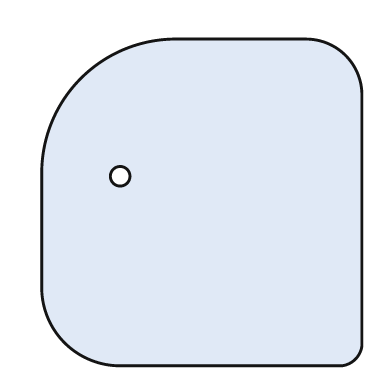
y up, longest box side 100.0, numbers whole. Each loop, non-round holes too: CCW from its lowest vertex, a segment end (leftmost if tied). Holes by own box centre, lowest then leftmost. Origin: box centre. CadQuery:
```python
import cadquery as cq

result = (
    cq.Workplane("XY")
    .moveTo(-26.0, -50.0)
    .lineTo(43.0, -50.0)
    .threePointArc((47.0, -48.0), (49.0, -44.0))
    .lineTo(49.0, 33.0)
    .threePointArc((44.0, 45.0), (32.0, 50.0))
    .lineTo(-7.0, 50.0)
    .threePointArc((-37.0, 38.0), (-49.0, 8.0))
    .lineTo(-49.0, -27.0)
    .threePointArc((-42.0, -43.0), (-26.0, -50.0))
    .close()
    .moveTo(-25.0, 8.0)
    .circle(3.0)
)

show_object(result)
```